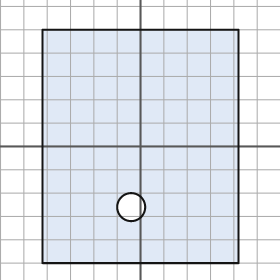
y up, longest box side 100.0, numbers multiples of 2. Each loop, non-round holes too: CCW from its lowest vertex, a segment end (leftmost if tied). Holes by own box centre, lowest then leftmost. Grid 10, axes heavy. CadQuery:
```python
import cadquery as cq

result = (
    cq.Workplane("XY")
    .moveTo(-42.0, -50.0)
    .lineTo(42.0, -50.0)
    .lineTo(42.0, 50.0)
    .lineTo(-42.0, 50.0)
    .close()
    .moveTo(-4.0, -26.0)
    .circle(6.0)
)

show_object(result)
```